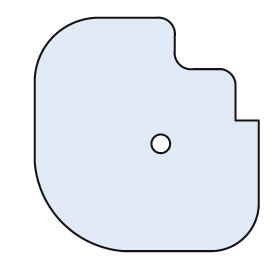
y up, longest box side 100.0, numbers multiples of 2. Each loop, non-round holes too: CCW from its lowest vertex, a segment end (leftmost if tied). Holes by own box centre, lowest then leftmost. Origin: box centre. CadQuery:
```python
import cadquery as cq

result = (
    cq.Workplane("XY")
    .moveTo(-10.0, -50.0)
    .lineTo(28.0, -50.0)
    .threePointArc((42.0, -44.0), (48.0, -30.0))
    .lineTo(48.0, 6.0)
    .lineTo(38.0, 6.0)
    .lineTo(38.0, 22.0)
    .threePointArc((36.0, 26.0), (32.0, 28.0))
    .lineTo(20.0, 28.0)
    .threePointArc((14.0, 30.0), (12.0, 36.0))
    .lineTo(12.0, 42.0)
    .threePointArc((10.0, 48.0), (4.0, 50.0))
    .lineTo(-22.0, 50.0)
    .threePointArc((-40.0, 42.0), (-48.0, 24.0))
    .lineTo(-48.0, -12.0)
    .threePointArc((-36.0, -38.0), (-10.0, -50.0))
    .close()
    .moveTo(6.0, -4.0)
    .circle(4.0)
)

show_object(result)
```